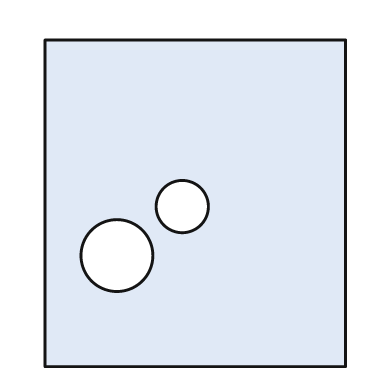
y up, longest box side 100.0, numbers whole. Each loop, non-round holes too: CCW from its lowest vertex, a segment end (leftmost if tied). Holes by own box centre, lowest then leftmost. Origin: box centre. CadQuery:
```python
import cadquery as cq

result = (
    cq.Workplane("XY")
    .moveTo(-46.0, -50.0)
    .lineTo(46.0, -50.0)
    .lineTo(46.0, 50.0)
    .lineTo(-46.0, 50.0)
    .close()
    .moveTo(-24.0, -16.0)
    .circle(11.0)
    .moveTo(-4.0, -1.0)
    .circle(8.0)
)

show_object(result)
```